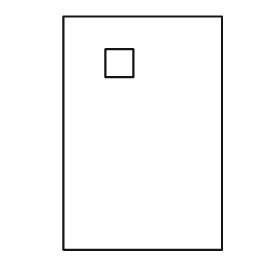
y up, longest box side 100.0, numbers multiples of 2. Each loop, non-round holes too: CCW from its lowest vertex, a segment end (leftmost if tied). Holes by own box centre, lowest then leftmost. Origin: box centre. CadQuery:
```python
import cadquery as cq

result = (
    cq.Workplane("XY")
    .moveTo(-34.0, -50.0)
    .lineTo(34.0, -50.0)
    .lineTo(34.0, 50.0)
    .lineTo(-34.0, 50.0)
    .close()
    .moveTo(-16.0, 24.0)
    .lineTo(-4.0, 24.0)
    .lineTo(-4.0, 36.0)
    .lineTo(-16.0, 36.0)
    .close()
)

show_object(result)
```